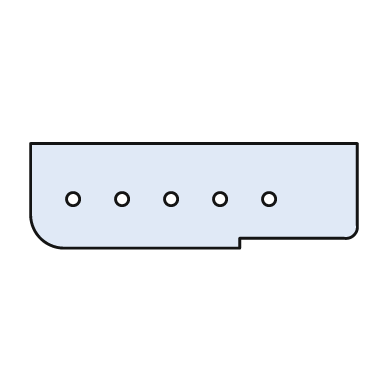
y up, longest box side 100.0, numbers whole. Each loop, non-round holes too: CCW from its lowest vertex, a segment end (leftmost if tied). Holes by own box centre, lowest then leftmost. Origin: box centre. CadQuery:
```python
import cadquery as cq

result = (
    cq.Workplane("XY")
    .moveTo(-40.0, -16.0)
    .lineTo(14.0, -16.0)
    .lineTo(14.0, -13.0)
    .lineTo(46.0, -13.0)
    .threePointArc((49.0, -12.0), (50.0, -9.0))
    .lineTo(50.0, 16.0)
    .lineTo(-50.0, 16.0)
    .lineTo(-50.0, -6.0)
    .threePointArc((-47.0, -13.0), (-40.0, -16.0))
    .close()
    .moveTo(-37.0, -1.0)
    .circle(2.0)
    .moveTo(-22.0, -1.0)
    .circle(2.0)
    .moveTo(-7.0, -1.0)
    .circle(2.0)
    .moveTo(8.0, -1.0)
    .circle(2.0)
    .moveTo(23.0, -1.0)
    .circle(2.0)
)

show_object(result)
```